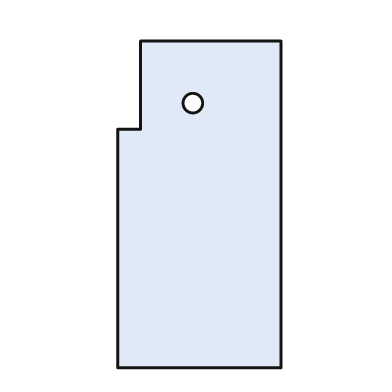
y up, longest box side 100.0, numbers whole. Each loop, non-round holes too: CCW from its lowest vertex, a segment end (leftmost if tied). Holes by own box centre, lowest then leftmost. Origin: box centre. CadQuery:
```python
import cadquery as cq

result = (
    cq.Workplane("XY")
    .moveTo(-25.0, -50.0)
    .lineTo(25.0, -50.0)
    .lineTo(25.0, 50.0)
    .lineTo(-18.0, 50.0)
    .lineTo(-18.0, 23.0)
    .lineTo(-25.0, 23.0)
    .close()
    .moveTo(-2.0, 31.0)
    .circle(3.0)
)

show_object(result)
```